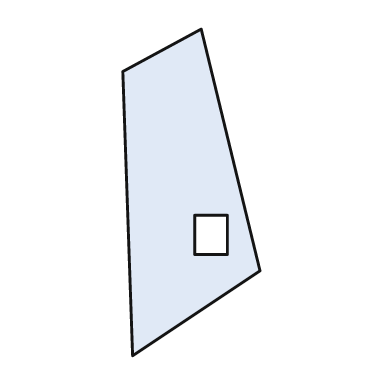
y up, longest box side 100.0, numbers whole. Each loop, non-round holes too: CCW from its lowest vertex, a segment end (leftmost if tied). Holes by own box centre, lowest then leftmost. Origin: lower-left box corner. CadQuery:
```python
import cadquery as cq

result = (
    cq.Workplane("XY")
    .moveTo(3.0, 0.0)
    .lineTo(42.0, 26.0)
    .lineTo(24.0, 100.0)
    .lineTo(0.0, 87.0)
    .close()
    .moveTo(22.0, 31.0)
    .lineTo(32.0, 31.0)
    .lineTo(32.0, 43.0)
    .lineTo(22.0, 43.0)
    .close()
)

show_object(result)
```